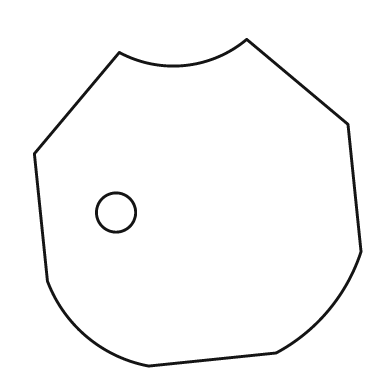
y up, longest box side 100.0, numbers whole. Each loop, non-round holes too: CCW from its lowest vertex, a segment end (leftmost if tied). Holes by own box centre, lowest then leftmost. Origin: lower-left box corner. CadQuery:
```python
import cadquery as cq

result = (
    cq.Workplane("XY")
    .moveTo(35.0, 0.0)
    .lineTo(74.0, 4.0)
    .threePointArc((90.0, 17.0), (100.0, 35.0))
    .lineTo(96.0, 74.0)
    .lineTo(65.0, 100.0)
    .threePointArc((46.0, 92.0), (26.0, 96.0))
    .lineTo(0.0, 65.0)
    .lineTo(4.0, 26.0)
    .threePointArc((16.0, 9.0), (35.0, 0.0))
    .close()
    .moveTo(25.0, 47.0)
    .circle(6.0)
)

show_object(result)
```